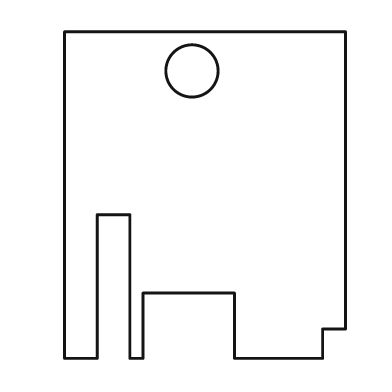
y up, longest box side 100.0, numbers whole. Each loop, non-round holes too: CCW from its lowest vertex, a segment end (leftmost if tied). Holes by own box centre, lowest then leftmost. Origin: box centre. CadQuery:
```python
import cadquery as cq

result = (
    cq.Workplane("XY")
    .moveTo(-43.0, -50.0)
    .lineTo(-33.0, -50.0)
    .lineTo(-33.0, -6.0)
    .lineTo(-23.0, -6.0)
    .lineTo(-23.0, -50.0)
    .lineTo(-19.0, -50.0)
    .lineTo(-19.0, -30.0)
    .lineTo(9.0, -30.0)
    .lineTo(9.0, -50.0)
    .lineTo(36.0, -50.0)
    .lineTo(36.0, -41.0)
    .lineTo(43.0, -41.0)
    .lineTo(43.0, 50.0)
    .lineTo(-43.0, 50.0)
    .close()
    .moveTo(-4.0, 38.0)
    .circle(8.0)
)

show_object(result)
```